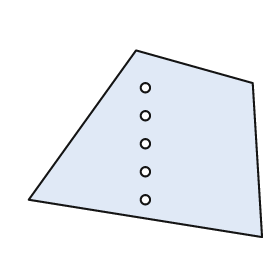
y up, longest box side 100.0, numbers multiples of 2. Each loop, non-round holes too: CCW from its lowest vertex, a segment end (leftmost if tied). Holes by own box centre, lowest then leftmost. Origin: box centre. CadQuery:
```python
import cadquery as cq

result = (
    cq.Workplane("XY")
    .moveTo(50.0, -40.0)
    .lineTo(46.0, 26.0)
    .lineTo(-4.0, 40.0)
    .lineTo(-50.0, -24.0)
    .close()
    .moveTo(0.0, -24.0)
    .circle(2.0)
    .moveTo(0.0, -12.0)
    .circle(2.0)
    .moveTo(0.0, 0.0)
    .circle(2.0)
    .moveTo(0.0, 12.0)
    .circle(2.0)
    .moveTo(0.0, 24.0)
    .circle(2.0)
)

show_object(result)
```